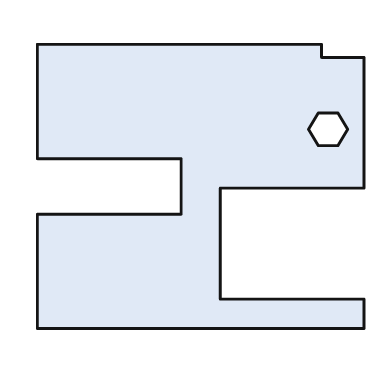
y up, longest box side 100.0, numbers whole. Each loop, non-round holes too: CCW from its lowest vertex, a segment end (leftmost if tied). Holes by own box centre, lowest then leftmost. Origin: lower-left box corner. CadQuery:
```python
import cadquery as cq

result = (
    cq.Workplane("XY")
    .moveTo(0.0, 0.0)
    .lineTo(100.0, 0.0)
    .lineTo(100.0, 9.0)
    .lineTo(56.0, 9.0)
    .lineTo(56.0, 43.0)
    .lineTo(100.0, 43.0)
    .lineTo(100.0, 83.0)
    .lineTo(87.0, 83.0)
    .lineTo(87.0, 87.0)
    .lineTo(0.0, 87.0)
    .lineTo(0.0, 52.0)
    .lineTo(44.0, 52.0)
    .lineTo(44.0, 35.0)
    .lineTo(0.0, 35.0)
    .close()
    .moveTo(86.0, 56.0)
    .lineTo(92.0, 56.0)
    .lineTo(95.0, 61.0)
    .lineTo(92.0, 66.0)
    .lineTo(86.0, 66.0)
    .lineTo(83.0, 61.0)
    .close()
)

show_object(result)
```